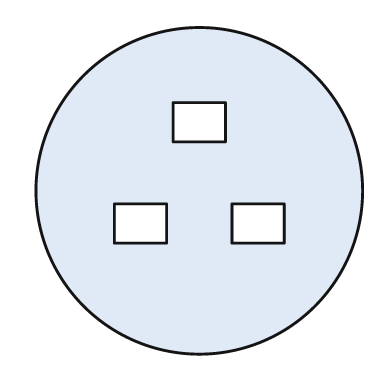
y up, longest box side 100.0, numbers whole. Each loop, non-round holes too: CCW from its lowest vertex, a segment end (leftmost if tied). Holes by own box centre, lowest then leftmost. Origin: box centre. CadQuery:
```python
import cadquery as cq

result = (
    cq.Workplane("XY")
    .moveTo(0.0, 0.0)
    .circle(50.0)
    .moveTo(-26.0, -16.0)
    .lineTo(-10.0, -16.0)
    .lineTo(-10.0, -4.0)
    .lineTo(-26.0, -4.0)
    .close()
    .moveTo(10.0, -16.0)
    .lineTo(26.0, -16.0)
    .lineTo(26.0, -4.0)
    .lineTo(10.0, -4.0)
    .close()
    .moveTo(-8.0, 15.0)
    .lineTo(8.0, 15.0)
    .lineTo(8.0, 27.0)
    .lineTo(-8.0, 27.0)
    .close()
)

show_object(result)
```